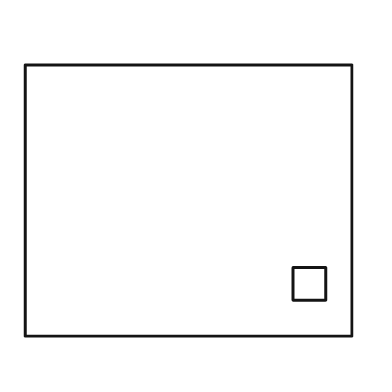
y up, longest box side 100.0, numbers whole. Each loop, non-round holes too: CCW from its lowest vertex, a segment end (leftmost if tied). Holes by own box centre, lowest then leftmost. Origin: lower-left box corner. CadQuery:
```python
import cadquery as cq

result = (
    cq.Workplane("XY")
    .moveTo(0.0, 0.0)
    .lineTo(100.0, 0.0)
    .lineTo(100.0, 83.0)
    .lineTo(0.0, 83.0)
    .close()
    .moveTo(82.0, 11.0)
    .lineTo(92.0, 11.0)
    .lineTo(92.0, 21.0)
    .lineTo(82.0, 21.0)
    .close()
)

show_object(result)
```